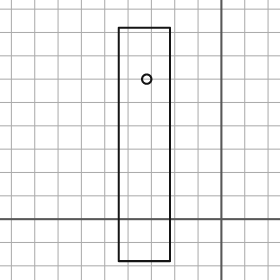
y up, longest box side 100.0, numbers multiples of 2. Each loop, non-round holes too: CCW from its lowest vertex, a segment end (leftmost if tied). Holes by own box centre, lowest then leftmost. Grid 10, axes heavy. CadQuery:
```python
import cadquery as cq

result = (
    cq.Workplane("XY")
    .moveTo(-44.0, -18.0)
    .lineTo(-22.0, -18.0)
    .lineTo(-22.0, 82.0)
    .lineTo(-44.0, 82.0)
    .close()
    .moveTo(-32.0, 60.0)
    .circle(2.0)
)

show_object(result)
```